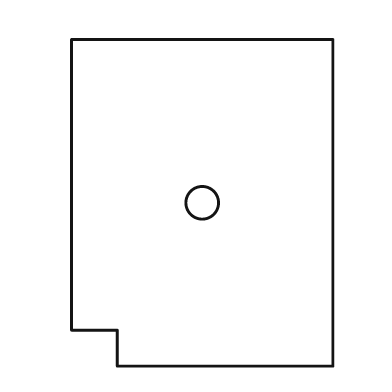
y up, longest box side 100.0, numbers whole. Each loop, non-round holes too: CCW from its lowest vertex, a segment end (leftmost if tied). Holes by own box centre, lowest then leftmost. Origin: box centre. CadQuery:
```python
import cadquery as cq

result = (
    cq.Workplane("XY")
    .moveTo(-26.0, -50.0)
    .lineTo(40.0, -50.0)
    .lineTo(40.0, 50.0)
    .lineTo(-40.0, 50.0)
    .lineTo(-40.0, -39.0)
    .lineTo(-26.0, -39.0)
    .close()
    .moveTo(0.0, 0.0)
    .circle(5.0)
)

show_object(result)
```